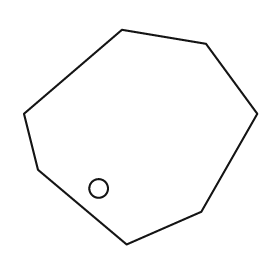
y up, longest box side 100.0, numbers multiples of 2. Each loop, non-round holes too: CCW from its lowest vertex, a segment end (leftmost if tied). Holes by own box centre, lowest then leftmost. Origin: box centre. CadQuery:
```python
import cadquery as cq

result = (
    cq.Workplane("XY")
    .moveTo(-6.0, -46.0)
    .lineTo(26.0, -32.0)
    .lineTo(50.0, 10.0)
    .lineTo(28.0, 40.0)
    .lineTo(-8.0, 46.0)
    .lineTo(-50.0, 10.0)
    .lineTo(-44.0, -14.0)
    .close()
    .moveTo(-18.0, -22.0)
    .circle(4.0)
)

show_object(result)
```